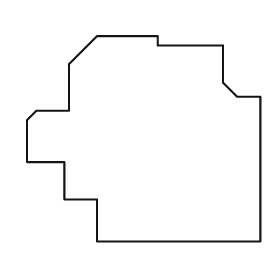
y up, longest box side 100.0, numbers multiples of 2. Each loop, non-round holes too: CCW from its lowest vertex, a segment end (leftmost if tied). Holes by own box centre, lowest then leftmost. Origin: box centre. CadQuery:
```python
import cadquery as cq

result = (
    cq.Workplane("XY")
    .moveTo(-20.0, -44.0)
    .lineTo(50.0, -44.0)
    .lineTo(50.0, 18.0)
    .lineTo(40.0, 18.0)
    .lineTo(34.0, 24.0)
    .lineTo(34.0, 40.0)
    .lineTo(6.0, 40.0)
    .lineTo(6.0, 44.0)
    .lineTo(-20.0, 44.0)
    .lineTo(-32.0, 32.0)
    .lineTo(-32.0, 12.0)
    .lineTo(-46.0, 12.0)
    .lineTo(-50.0, 8.0)
    .lineTo(-50.0, -10.0)
    .lineTo(-34.0, -10.0)
    .lineTo(-34.0, -26.0)
    .lineTo(-20.0, -26.0)
    .close()
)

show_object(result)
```